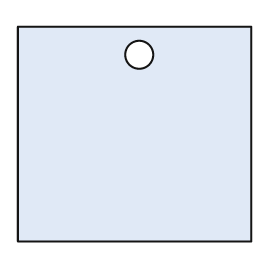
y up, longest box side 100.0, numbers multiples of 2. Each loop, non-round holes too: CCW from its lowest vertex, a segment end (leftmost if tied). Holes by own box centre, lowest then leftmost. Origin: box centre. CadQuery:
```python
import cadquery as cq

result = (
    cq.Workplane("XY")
    .moveTo(-50.0, -46.0)
    .lineTo(50.0, -46.0)
    .lineTo(50.0, 46.0)
    .lineTo(-50.0, 46.0)
    .close()
    .moveTo(2.0, 34.0)
    .circle(6.0)
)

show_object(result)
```